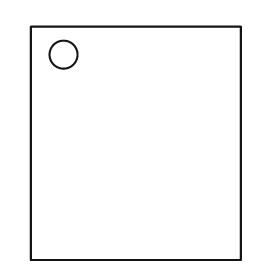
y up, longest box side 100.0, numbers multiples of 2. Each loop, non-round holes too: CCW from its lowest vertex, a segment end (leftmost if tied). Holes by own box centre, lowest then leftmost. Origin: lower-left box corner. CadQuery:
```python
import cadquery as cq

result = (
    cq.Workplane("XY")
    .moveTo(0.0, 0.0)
    .lineTo(90.0, 0.0)
    .lineTo(90.0, 100.0)
    .lineTo(0.0, 100.0)
    .close()
    .moveTo(14.0, 88.0)
    .circle(6.0)
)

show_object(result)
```